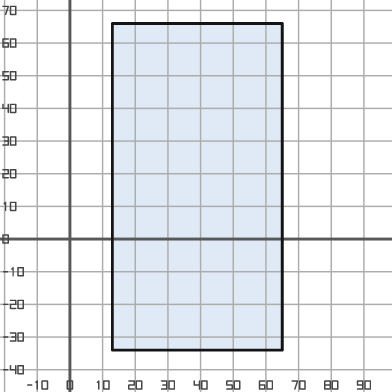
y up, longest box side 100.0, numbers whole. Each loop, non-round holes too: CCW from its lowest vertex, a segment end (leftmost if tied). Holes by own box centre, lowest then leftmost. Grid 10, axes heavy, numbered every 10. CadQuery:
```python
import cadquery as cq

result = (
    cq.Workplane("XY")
    .moveTo(13.0, -34.0)
    .lineTo(65.0, -34.0)
    .lineTo(65.0, 66.0)
    .lineTo(13.0, 66.0)
    .close()
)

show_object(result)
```